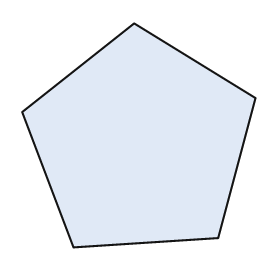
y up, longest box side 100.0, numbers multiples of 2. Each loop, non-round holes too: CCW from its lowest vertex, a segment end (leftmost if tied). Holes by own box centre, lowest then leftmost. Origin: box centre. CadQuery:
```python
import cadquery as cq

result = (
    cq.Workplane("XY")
    .moveTo(-28.0, -48.0)
    .lineTo(34.0, -44.0)
    .lineTo(50.0, 16.0)
    .lineTo(-2.0, 48.0)
    .lineTo(-50.0, 10.0)
    .close()
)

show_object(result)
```